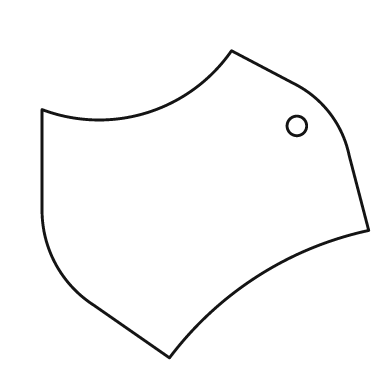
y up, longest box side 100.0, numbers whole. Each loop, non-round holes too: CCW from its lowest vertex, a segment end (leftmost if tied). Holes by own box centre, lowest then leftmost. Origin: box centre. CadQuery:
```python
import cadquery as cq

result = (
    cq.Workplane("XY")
    .moveTo(-11.0, -47.0)
    .threePointArc((16.0, -22.0), (50.0, -8.0))
    .lineTo(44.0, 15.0)
    .threePointArc((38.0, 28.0), (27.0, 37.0))
    .lineTo(8.0, 47.0)
    .threePointArc((-18.0, 28.0), (-50.0, 29.0))
    .lineTo(-50.0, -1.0)
    .threePointArc((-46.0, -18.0), (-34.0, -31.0))
    .close()
    .moveTo(28.0, 24.0)
    .circle(3.0)
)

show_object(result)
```